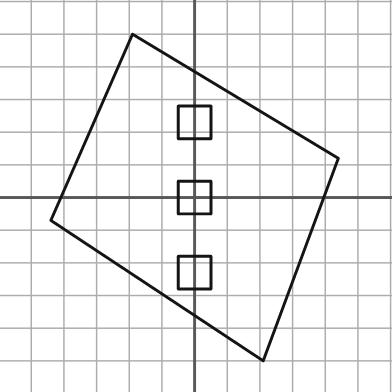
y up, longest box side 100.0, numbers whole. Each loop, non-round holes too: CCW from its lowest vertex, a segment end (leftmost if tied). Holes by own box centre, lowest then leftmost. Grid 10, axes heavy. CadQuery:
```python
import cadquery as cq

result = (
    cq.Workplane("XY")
    .moveTo(21.0, -50.0)
    .lineTo(44.0, 12.0)
    .lineTo(-19.0, 50.0)
    .lineTo(-44.0, -7.0)
    .close()
    .moveTo(-5.0, -28.0)
    .lineTo(5.0, -28.0)
    .lineTo(5.0, -18.0)
    .lineTo(-5.0, -18.0)
    .close()
    .moveTo(-5.0, -5.0)
    .lineTo(5.0, -5.0)
    .lineTo(5.0, 5.0)
    .lineTo(-5.0, 5.0)
    .close()
    .moveTo(-5.0, 18.0)
    .lineTo(5.0, 18.0)
    .lineTo(5.0, 28.0)
    .lineTo(-5.0, 28.0)
    .close()
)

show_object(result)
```